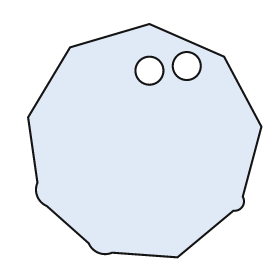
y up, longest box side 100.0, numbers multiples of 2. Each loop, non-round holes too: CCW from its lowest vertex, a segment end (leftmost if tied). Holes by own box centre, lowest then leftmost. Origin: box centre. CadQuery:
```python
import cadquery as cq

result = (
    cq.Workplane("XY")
    .moveTo(14.0, -50.0)
    .lineTo(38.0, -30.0)
    .threePointArc((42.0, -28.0), (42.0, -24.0))
    .lineTo(50.0, 6.0)
    .lineTo(34.0, 36.0)
    .lineTo(2.0, 50.0)
    .lineTo(-32.0, 40.0)
    .lineTo(-50.0, 10.0)
    .lineTo(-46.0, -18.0)
    .threePointArc((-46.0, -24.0), (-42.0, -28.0))
    .lineTo(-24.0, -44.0)
    .threePointArc((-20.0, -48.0), (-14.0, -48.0))
    .close()
    .moveTo(2.0, 30.0)
    .circle(6.0)
    .moveTo(18.0, 32.0)
    .circle(6.0)
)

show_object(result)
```